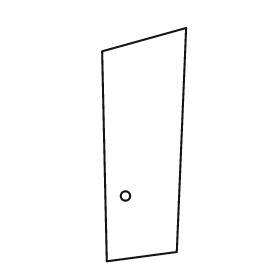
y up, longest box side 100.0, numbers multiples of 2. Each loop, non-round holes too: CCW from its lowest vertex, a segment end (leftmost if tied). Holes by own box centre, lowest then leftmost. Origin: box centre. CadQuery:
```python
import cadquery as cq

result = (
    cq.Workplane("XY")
    .moveTo(-16.0, -50.0)
    .lineTo(14.0, -46.0)
    .lineTo(18.0, 50.0)
    .lineTo(-18.0, 40.0)
    .close()
    .moveTo(-8.0, -22.0)
    .circle(2.0)
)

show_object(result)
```